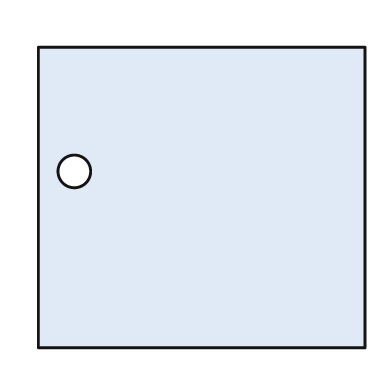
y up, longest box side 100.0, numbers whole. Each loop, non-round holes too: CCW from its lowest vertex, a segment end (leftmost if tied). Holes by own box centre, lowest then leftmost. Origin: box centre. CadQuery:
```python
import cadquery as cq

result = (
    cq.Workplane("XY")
    .moveTo(-50.0, -46.0)
    .lineTo(50.0, -46.0)
    .lineTo(50.0, 46.0)
    .lineTo(-50.0, 46.0)
    .close()
    .moveTo(-39.0, 8.0)
    .circle(5.0)
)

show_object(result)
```